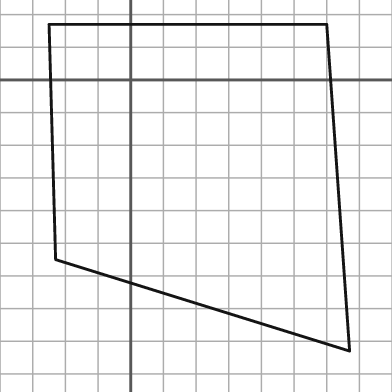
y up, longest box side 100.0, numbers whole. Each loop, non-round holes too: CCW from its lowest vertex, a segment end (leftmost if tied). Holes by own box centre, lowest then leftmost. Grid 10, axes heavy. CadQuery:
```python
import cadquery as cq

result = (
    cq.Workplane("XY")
    .moveTo(67.0, -83.0)
    .lineTo(60.0, 17.0)
    .lineTo(-25.0, 17.0)
    .lineTo(-23.0, -55.0)
    .close()
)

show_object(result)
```